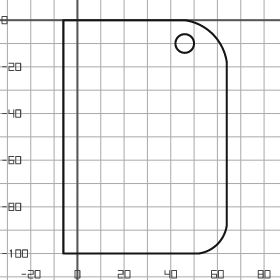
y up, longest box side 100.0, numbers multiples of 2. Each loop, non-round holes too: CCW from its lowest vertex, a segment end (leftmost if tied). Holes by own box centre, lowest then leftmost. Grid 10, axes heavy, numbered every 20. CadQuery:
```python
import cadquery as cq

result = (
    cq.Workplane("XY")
    .moveTo(-6.0, -100.0)
    .lineTo(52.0, -100.0)
    .threePointArc((60.0, -96.0), (64.0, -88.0))
    .lineTo(64.0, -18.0)
    .threePointArc((58.0, -6.0), (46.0, 0.0))
    .lineTo(-6.0, 0.0)
    .close()
    .moveTo(46.0, -10.0)
    .circle(4.0)
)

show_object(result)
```